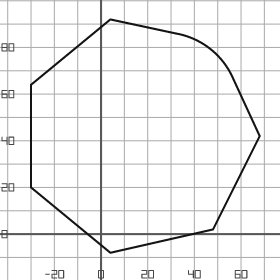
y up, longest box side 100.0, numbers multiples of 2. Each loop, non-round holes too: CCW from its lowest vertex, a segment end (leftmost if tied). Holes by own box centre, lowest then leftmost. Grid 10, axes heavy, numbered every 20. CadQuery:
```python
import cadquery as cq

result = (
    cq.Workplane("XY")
    .moveTo(4.0, -8.0)
    .lineTo(48.0, 2.0)
    .lineTo(68.0, 42.0)
    .lineTo(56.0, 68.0)
    .threePointArc((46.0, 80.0), (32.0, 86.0))
    .lineTo(4.0, 92.0)
    .lineTo(-30.0, 64.0)
    .lineTo(-30.0, 20.0)
    .close()
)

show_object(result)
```